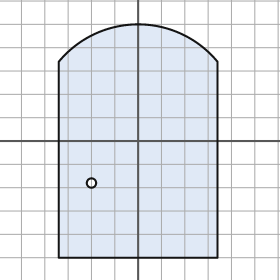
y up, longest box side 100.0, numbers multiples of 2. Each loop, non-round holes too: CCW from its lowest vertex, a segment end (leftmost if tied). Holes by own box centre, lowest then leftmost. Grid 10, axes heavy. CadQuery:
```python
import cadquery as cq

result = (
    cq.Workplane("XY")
    .moveTo(-34.0, -50.0)
    .lineTo(34.0, -50.0)
    .lineTo(34.0, 34.0)
    .threePointArc((0.0, 50.0), (-34.0, 34.0))
    .close()
    .moveTo(-20.0, -18.0)
    .circle(2.0)
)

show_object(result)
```